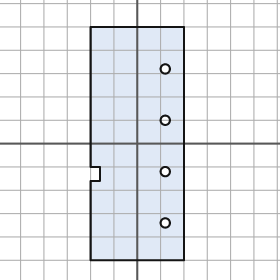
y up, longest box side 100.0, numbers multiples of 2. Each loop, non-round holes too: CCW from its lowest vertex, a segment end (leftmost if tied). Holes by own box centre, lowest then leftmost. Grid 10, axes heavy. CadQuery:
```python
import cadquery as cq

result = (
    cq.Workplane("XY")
    .moveTo(-20.0, -50.0)
    .lineTo(20.0, -50.0)
    .lineTo(20.0, 50.0)
    .lineTo(-20.0, 50.0)
    .lineTo(-20.0, -10.0)
    .lineTo(-16.0, -10.0)
    .lineTo(-16.0, -16.0)
    .lineTo(-20.0, -16.0)
    .close()
    .moveTo(12.0, -34.0)
    .circle(2.0)
    .moveTo(12.0, -12.0)
    .circle(2.0)
    .moveTo(12.0, 10.0)
    .circle(2.0)
    .moveTo(12.0, 32.0)
    .circle(2.0)
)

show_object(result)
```